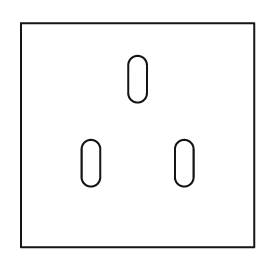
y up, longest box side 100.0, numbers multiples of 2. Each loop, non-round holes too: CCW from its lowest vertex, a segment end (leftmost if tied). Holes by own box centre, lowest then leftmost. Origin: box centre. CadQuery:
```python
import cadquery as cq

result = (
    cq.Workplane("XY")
    .moveTo(-50.0, -48.0)
    .lineTo(50.0, -48.0)
    .lineTo(50.0, 48.0)
    .lineTo(-50.0, 48.0)
    .close()
    .moveTo(-24.0, -18.0)
    .threePointArc((-20.0, -22.0), (-16.0, -18.0))
    .lineTo(-16.0, -6.0)
    .threePointArc((-20.0, -2.0), (-24.0, -6.0))
    .close()
    .moveTo(16.0, -18.0)
    .threePointArc((20.0, -22.0), (24.0, -18.0))
    .lineTo(24.0, -6.0)
    .threePointArc((20.0, -2.0), (16.0, -6.0))
    .close()
    .moveTo(-4.0, 18.0)
    .threePointArc((0.0, 14.0), (4.0, 18.0))
    .lineTo(4.0, 30.0)
    .threePointArc((0.0, 34.0), (-4.0, 30.0))
    .close()
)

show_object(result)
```